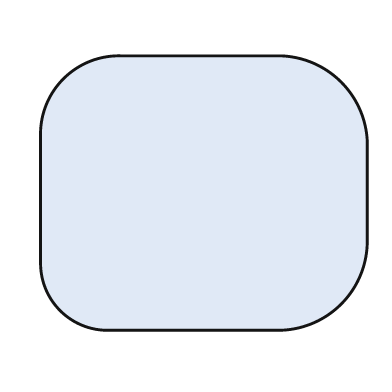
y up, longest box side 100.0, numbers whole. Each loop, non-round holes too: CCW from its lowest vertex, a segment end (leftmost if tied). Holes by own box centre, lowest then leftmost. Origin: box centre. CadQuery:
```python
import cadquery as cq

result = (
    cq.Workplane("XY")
    .moveTo(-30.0, -42.0)
    .lineTo(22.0, -42.0)
    .threePointArc((42.0, -34.0), (50.0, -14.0))
    .lineTo(50.0, 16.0)
    .threePointArc((42.0, 34.0), (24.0, 42.0))
    .lineTo(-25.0, 42.0)
    .threePointArc((-43.0, 35.0), (-50.0, 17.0))
    .lineTo(-50.0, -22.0)
    .threePointArc((-44.0, -36.0), (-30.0, -42.0))
    .close()
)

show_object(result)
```